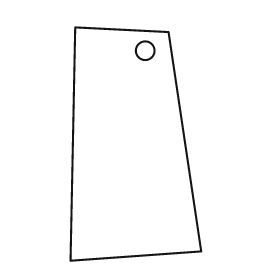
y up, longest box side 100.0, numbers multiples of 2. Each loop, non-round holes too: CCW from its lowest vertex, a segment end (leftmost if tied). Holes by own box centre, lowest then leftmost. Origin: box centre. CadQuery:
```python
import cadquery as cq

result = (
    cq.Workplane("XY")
    .moveTo(-28.0, -50.0)
    .lineTo(28.0, -46.0)
    .lineTo(14.0, 48.0)
    .lineTo(-26.0, 50.0)
    .close()
    .moveTo(4.0, 40.0)
    .circle(4.0)
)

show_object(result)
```